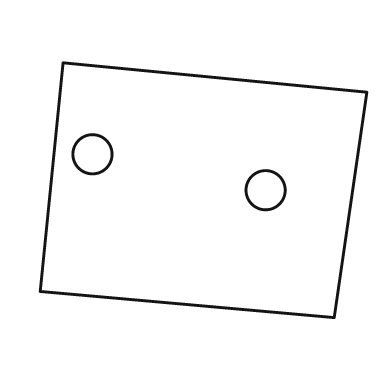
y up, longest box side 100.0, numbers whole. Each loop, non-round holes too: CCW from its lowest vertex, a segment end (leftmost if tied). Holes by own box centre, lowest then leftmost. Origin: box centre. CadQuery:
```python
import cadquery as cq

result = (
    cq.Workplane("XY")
    .moveTo(40.0, -39.0)
    .lineTo(50.0, 30.0)
    .lineTo(-43.0, 39.0)
    .lineTo(-50.0, -31.0)
    .close()
    .moveTo(19.0, 0.0)
    .circle(6.0)
    .moveTo(-34.0, 11.0)
    .circle(6.0)
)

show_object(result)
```